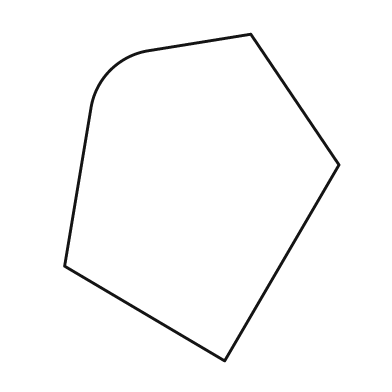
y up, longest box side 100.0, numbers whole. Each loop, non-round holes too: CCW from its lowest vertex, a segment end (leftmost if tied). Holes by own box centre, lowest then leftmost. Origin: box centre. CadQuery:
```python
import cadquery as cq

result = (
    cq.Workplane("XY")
    .moveTo(7.0, -50.0)
    .lineTo(42.0, 10.0)
    .lineTo(15.0, 50.0)
    .lineTo(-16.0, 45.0)
    .threePointArc((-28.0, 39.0), (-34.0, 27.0))
    .lineTo(-42.0, -21.0)
    .close()
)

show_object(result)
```